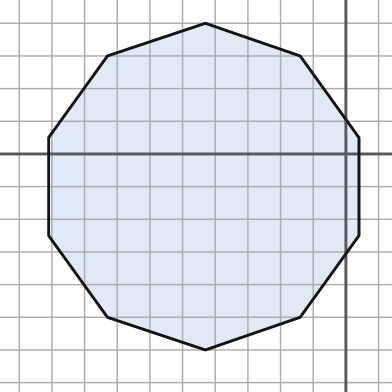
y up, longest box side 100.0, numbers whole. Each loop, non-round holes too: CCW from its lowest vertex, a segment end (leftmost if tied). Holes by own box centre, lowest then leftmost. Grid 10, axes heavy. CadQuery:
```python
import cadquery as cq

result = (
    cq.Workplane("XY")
    .moveTo(-43.0, -60.0)
    .lineTo(-14.0, -50.0)
    .lineTo(4.0, -25.0)
    .lineTo(4.0, 5.0)
    .lineTo(-14.0, 30.0)
    .lineTo(-43.0, 40.0)
    .lineTo(-73.0, 30.0)
    .lineTo(-91.0, 5.0)
    .lineTo(-91.0, -25.0)
    .lineTo(-73.0, -50.0)
    .close()
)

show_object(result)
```